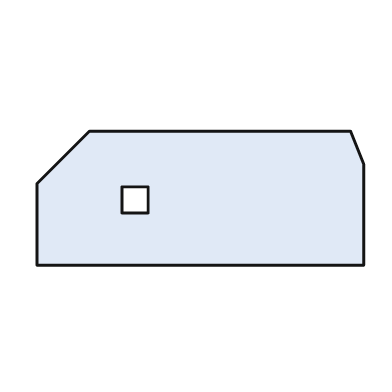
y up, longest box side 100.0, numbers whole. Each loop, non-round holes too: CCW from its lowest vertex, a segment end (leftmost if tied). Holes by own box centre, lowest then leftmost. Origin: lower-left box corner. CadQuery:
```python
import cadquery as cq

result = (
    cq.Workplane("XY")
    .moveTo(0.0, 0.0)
    .lineTo(100.0, 0.0)
    .lineTo(100.0, 31.0)
    .lineTo(96.0, 41.0)
    .lineTo(16.0, 41.0)
    .lineTo(0.0, 25.0)
    .close()
    .moveTo(26.0, 16.0)
    .lineTo(34.0, 16.0)
    .lineTo(34.0, 24.0)
    .lineTo(26.0, 24.0)
    .close()
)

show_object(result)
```